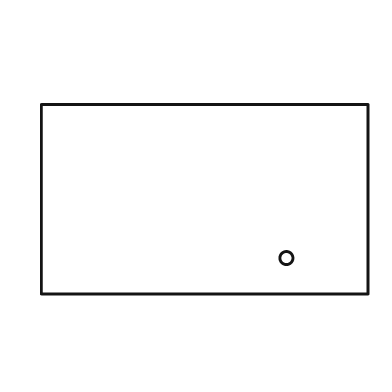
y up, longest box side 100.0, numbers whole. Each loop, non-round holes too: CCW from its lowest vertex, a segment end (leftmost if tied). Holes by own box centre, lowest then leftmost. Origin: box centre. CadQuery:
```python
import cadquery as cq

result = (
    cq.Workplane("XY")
    .moveTo(-50.0, -29.0)
    .lineTo(50.0, -29.0)
    .lineTo(50.0, 29.0)
    .lineTo(-50.0, 29.0)
    .close()
    .moveTo(25.0, -18.0)
    .circle(2.0)
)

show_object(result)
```